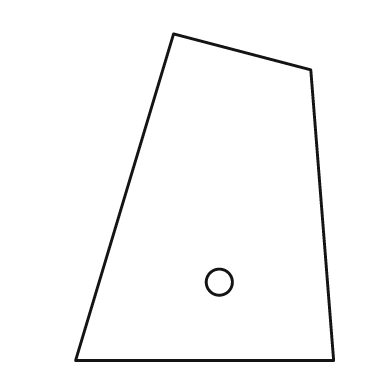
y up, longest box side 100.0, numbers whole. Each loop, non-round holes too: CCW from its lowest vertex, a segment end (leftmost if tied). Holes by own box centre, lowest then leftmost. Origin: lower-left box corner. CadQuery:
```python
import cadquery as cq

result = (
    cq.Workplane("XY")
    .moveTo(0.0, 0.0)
    .lineTo(79.0, 0.0)
    .lineTo(72.0, 89.0)
    .lineTo(30.0, 100.0)
    .close()
    .moveTo(44.0, 24.0)
    .circle(4.0)
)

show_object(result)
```